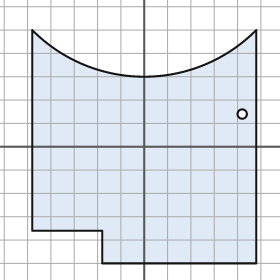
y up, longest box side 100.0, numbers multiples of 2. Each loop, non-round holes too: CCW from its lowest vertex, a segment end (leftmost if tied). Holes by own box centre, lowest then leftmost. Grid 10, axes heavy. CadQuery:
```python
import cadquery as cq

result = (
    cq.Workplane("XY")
    .moveTo(-18.0, -50.0)
    .lineTo(48.0, -50.0)
    .lineTo(48.0, 50.0)
    .threePointArc((0.0, 30.0), (-48.0, 50.0))
    .lineTo(-48.0, -36.0)
    .lineTo(-18.0, -36.0)
    .close()
    .moveTo(42.0, 14.0)
    .circle(2.0)
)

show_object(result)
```